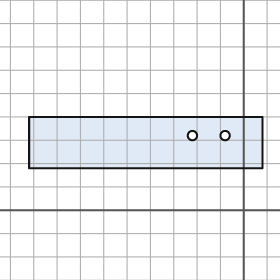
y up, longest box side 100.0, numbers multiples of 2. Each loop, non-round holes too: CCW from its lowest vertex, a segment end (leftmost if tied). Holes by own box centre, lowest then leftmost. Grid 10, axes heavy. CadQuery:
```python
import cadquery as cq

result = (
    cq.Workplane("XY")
    .moveTo(-92.0, 18.0)
    .lineTo(8.0, 18.0)
    .lineTo(8.0, 40.0)
    .lineTo(-92.0, 40.0)
    .close()
    .moveTo(-22.0, 32.0)
    .circle(2.0)
    .moveTo(-8.0, 32.0)
    .circle(2.0)
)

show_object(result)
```